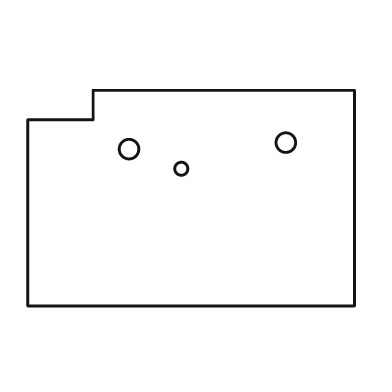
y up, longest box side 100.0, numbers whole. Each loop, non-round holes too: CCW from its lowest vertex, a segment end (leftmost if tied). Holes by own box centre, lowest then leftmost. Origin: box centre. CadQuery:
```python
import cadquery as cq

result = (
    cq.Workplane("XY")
    .moveTo(-50.0, -33.0)
    .lineTo(50.0, -33.0)
    .lineTo(50.0, 33.0)
    .lineTo(-30.0, 33.0)
    .lineTo(-30.0, 24.0)
    .lineTo(-50.0, 24.0)
    .close()
    .moveTo(-3.0, 9.0)
    .circle(2.0)
    .moveTo(-19.0, 15.0)
    .circle(3.0)
    .moveTo(29.0, 17.0)
    .circle(3.0)
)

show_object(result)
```